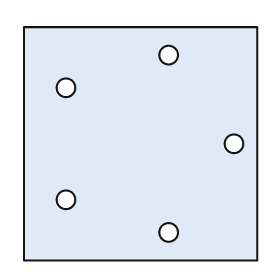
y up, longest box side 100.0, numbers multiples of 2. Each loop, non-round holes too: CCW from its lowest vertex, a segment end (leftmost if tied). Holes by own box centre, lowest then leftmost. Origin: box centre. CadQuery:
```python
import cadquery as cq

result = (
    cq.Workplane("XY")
    .moveTo(-50.0, -50.0)
    .lineTo(50.0, -50.0)
    .lineTo(50.0, 50.0)
    .lineTo(-50.0, 50.0)
    .close()
    .moveTo(12.0, -38.0)
    .circle(4.0)
    .moveTo(-32.0, -24.0)
    .circle(4.0)
    .moveTo(40.0, 0.0)
    .circle(4.0)
    .moveTo(-32.0, 24.0)
    .circle(4.0)
    .moveTo(12.0, 38.0)
    .circle(4.0)
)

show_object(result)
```